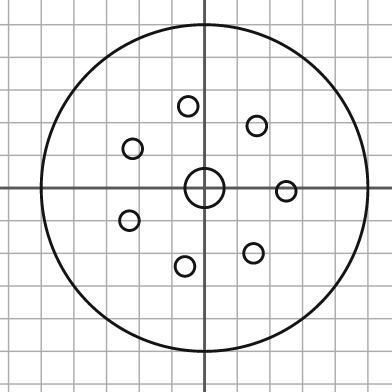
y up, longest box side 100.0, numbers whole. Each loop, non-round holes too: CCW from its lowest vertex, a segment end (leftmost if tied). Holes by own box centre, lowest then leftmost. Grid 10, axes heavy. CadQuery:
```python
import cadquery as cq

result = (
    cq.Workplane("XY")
    .moveTo(0.0, 0.0)
    .circle(50.0)
    .moveTo(-6.0, -24.0)
    .circle(3.0)
    .moveTo(15.0, -20.0)
    .circle(3.0)
    .moveTo(-23.0, -10.0)
    .circle(3.0)
    .moveTo(25.0, -1.0)
    .circle(3.0)
    .moveTo(0.0, 0.0)
    .circle(6.0)
    .moveTo(-22.0, 12.0)
    .circle(3.0)
    .moveTo(16.0, 19.0)
    .circle(3.0)
    .moveTo(-5.0, 25.0)
    .circle(3.0)
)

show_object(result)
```